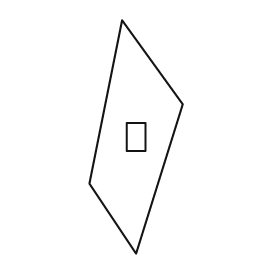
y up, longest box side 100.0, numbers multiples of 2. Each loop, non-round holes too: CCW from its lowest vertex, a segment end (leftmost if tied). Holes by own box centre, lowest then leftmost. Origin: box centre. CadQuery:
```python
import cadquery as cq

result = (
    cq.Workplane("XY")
    .moveTo(0.0, -50.0)
    .lineTo(20.0, 14.0)
    .lineTo(-6.0, 50.0)
    .lineTo(-20.0, -20.0)
    .close()
    .moveTo(-4.0, -6.0)
    .lineTo(4.0, -6.0)
    .lineTo(4.0, 6.0)
    .lineTo(-4.0, 6.0)
    .close()
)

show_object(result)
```